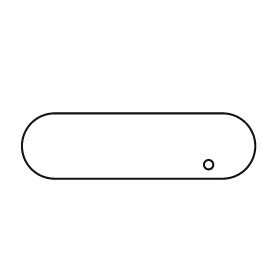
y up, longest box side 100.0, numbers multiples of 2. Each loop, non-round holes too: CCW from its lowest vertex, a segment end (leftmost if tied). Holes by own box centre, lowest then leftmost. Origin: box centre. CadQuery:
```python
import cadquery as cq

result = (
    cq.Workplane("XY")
    .moveTo(-36.0, -14.0)
    .lineTo(36.0, -14.0)
    .threePointArc((50.0, 0.0), (36.0, 14.0))
    .lineTo(-36.0, 14.0)
    .threePointArc((-50.0, 0.0), (-36.0, -14.0))
    .close()
    .moveTo(30.0, -8.0)
    .circle(2.0)
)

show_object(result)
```